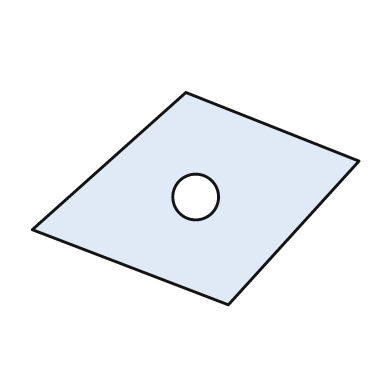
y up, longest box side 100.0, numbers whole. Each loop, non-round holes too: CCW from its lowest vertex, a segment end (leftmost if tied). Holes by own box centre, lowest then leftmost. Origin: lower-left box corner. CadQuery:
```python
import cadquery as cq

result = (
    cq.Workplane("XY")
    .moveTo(60.0, 0.0)
    .lineTo(100.0, 44.0)
    .lineTo(47.0, 65.0)
    .lineTo(0.0, 23.0)
    .close()
    .moveTo(50.0, 33.0)
    .circle(7.0)
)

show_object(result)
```